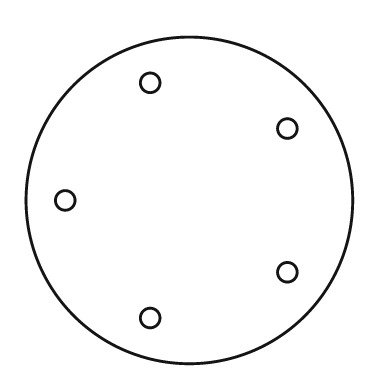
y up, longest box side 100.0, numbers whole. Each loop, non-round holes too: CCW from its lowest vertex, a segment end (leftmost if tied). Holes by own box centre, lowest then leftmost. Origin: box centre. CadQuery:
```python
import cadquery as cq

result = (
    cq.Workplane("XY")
    .moveTo(0.0, 0.0)
    .circle(50.0)
    .moveTo(-12.0, -36.0)
    .circle(3.0)
    .moveTo(30.0, -22.0)
    .circle(3.0)
    .moveTo(-38.0, 0.0)
    .circle(3.0)
    .moveTo(30.0, 22.0)
    .circle(3.0)
    .moveTo(-12.0, 36.0)
    .circle(3.0)
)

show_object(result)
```